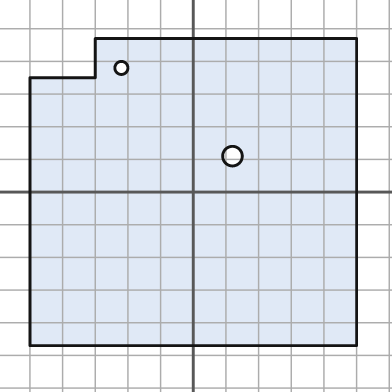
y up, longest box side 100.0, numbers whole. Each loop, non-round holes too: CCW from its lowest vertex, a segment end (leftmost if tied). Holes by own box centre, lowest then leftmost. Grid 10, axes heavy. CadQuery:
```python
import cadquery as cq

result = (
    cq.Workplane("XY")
    .moveTo(-50.0, -47.0)
    .lineTo(50.0, -47.0)
    .lineTo(50.0, 47.0)
    .lineTo(-30.0, 47.0)
    .lineTo(-30.0, 35.0)
    .lineTo(-50.0, 35.0)
    .close()
    .moveTo(12.0, 11.0)
    .circle(3.0)
    .moveTo(-22.0, 38.0)
    .circle(2.0)
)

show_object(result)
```